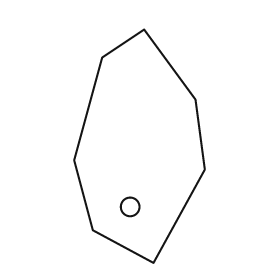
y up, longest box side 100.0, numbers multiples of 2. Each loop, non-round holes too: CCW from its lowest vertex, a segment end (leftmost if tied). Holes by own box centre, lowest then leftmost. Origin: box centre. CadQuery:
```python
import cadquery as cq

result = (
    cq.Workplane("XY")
    .moveTo(6.0, -50.0)
    .lineTo(28.0, -10.0)
    .lineTo(24.0, 20.0)
    .lineTo(2.0, 50.0)
    .lineTo(-16.0, 38.0)
    .lineTo(-28.0, -6.0)
    .lineTo(-20.0, -36.0)
    .close()
    .moveTo(-4.0, -26.0)
    .circle(4.0)
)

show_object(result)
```